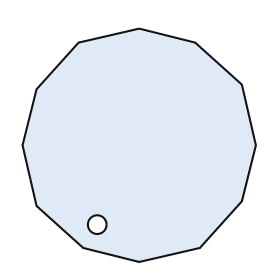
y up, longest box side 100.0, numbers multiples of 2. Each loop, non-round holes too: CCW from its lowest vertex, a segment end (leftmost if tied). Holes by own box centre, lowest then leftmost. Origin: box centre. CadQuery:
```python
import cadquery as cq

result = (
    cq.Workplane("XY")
    .moveTo(0.0, -50.0)
    .lineTo(26.0, -44.0)
    .lineTo(44.0, -24.0)
    .lineTo(50.0, 0.0)
    .lineTo(44.0, 26.0)
    .lineTo(24.0, 44.0)
    .lineTo(0.0, 50.0)
    .lineTo(-26.0, 44.0)
    .lineTo(-44.0, 24.0)
    .lineTo(-50.0, 0.0)
    .lineTo(-44.0, -26.0)
    .lineTo(-24.0, -44.0)
    .close()
    .moveTo(-18.0, -34.0)
    .circle(4.0)
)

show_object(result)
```